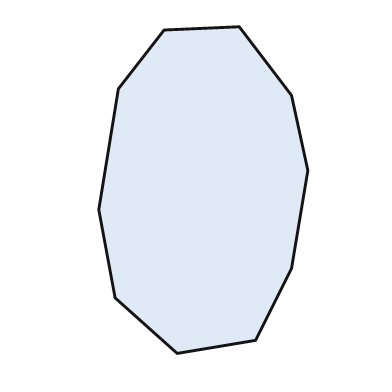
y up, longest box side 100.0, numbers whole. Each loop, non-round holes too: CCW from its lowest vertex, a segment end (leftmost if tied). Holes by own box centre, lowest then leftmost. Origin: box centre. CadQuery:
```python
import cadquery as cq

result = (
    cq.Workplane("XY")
    .moveTo(-8.0, -50.0)
    .lineTo(16.0, -46.0)
    .lineTo(27.0, -24.0)
    .lineTo(32.0, 6.0)
    .lineTo(27.0, 29.0)
    .lineTo(11.0, 50.0)
    .lineTo(-12.0, 49.0)
    .lineTo(-26.0, 31.0)
    .lineTo(-32.0, -6.0)
    .lineTo(-27.0, -33.0)
    .close()
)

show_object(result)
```